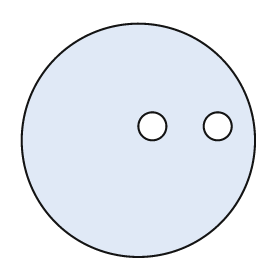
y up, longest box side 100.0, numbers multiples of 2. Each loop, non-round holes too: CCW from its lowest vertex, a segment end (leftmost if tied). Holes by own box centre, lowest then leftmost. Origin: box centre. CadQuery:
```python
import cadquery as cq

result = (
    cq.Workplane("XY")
    .moveTo(0.0, 0.0)
    .circle(50.0)
    .moveTo(6.0, 6.0)
    .circle(6.0)
    .moveTo(34.0, 6.0)
    .circle(6.0)
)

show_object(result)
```